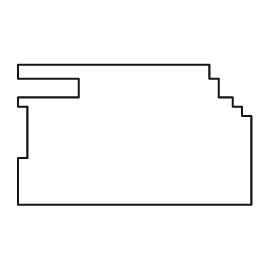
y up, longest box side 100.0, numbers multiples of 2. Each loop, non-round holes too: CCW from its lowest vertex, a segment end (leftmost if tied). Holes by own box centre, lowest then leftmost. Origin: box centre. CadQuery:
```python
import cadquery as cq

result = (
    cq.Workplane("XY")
    .moveTo(-50.0, -30.0)
    .lineTo(50.0, -30.0)
    .lineTo(50.0, 8.0)
    .lineTo(46.0, 8.0)
    .lineTo(46.0, 12.0)
    .lineTo(42.0, 12.0)
    .lineTo(42.0, 16.0)
    .lineTo(36.0, 16.0)
    .lineTo(36.0, 24.0)
    .lineTo(32.0, 24.0)
    .lineTo(32.0, 30.0)
    .lineTo(-50.0, 30.0)
    .lineTo(-50.0, 24.0)
    .lineTo(-24.0, 24.0)
    .lineTo(-24.0, 16.0)
    .lineTo(-50.0, 16.0)
    .lineTo(-50.0, 12.0)
    .lineTo(-46.0, 12.0)
    .lineTo(-46.0, -10.0)
    .lineTo(-50.0, -10.0)
    .close()
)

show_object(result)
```